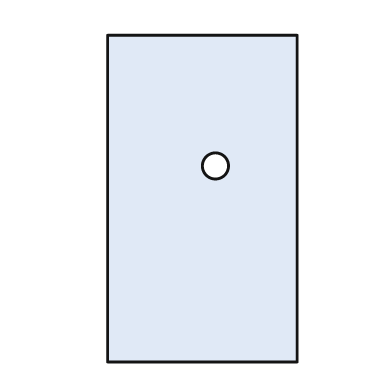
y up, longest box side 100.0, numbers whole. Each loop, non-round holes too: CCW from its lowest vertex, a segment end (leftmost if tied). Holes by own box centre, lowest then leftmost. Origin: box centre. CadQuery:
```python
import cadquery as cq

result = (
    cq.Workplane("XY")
    .moveTo(-29.0, -50.0)
    .lineTo(29.0, -50.0)
    .lineTo(29.0, 50.0)
    .lineTo(-29.0, 50.0)
    .close()
    .moveTo(4.0, 10.0)
    .circle(4.0)
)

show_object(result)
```